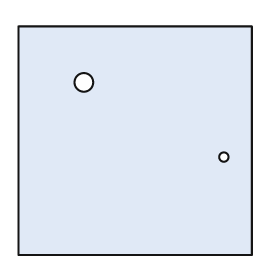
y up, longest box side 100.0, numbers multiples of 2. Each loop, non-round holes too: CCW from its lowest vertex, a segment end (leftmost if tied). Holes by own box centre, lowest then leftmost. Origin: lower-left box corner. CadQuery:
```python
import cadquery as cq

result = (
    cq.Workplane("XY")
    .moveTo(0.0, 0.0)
    .lineTo(100.0, 0.0)
    .lineTo(100.0, 98.0)
    .lineTo(0.0, 98.0)
    .close()
    .moveTo(88.0, 42.0)
    .circle(2.0)
    .moveTo(28.0, 74.0)
    .circle(4.0)
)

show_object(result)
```